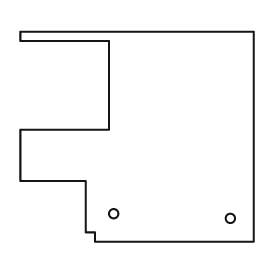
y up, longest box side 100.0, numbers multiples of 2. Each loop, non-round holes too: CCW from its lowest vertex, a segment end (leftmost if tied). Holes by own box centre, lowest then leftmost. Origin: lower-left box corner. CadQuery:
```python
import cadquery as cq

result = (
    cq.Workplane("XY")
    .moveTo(32.0, 0.0)
    .lineTo(100.0, 0.0)
    .lineTo(100.0, 90.0)
    .lineTo(0.0, 90.0)
    .lineTo(0.0, 86.0)
    .lineTo(38.0, 86.0)
    .lineTo(38.0, 48.0)
    .lineTo(0.0, 48.0)
    .lineTo(0.0, 26.0)
    .lineTo(28.0, 26.0)
    .lineTo(28.0, 4.0)
    .lineTo(32.0, 4.0)
    .close()
    .moveTo(90.0, 10.0)
    .circle(2.0)
    .moveTo(40.0, 12.0)
    .circle(2.0)
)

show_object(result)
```